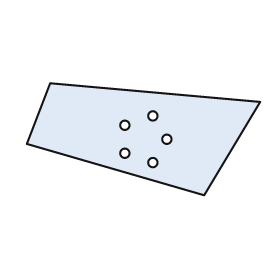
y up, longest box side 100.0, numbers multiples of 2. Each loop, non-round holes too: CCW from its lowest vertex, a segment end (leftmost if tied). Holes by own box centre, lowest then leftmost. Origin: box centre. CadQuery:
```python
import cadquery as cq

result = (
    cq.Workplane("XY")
    .moveTo(26.0, -24.0)
    .lineTo(50.0, 16.0)
    .lineTo(-40.0, 24.0)
    .lineTo(-50.0, -2.0)
    .close()
    .moveTo(4.0, -10.0)
    .circle(2.0)
    .moveTo(-8.0, -6.0)
    .circle(2.0)
    .moveTo(10.0, 0.0)
    .circle(2.0)
    .moveTo(-8.0, 6.0)
    .circle(2.0)
    .moveTo(4.0, 10.0)
    .circle(2.0)
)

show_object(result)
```